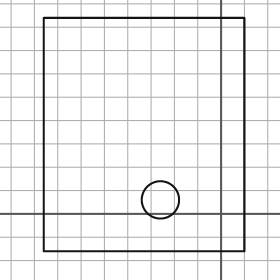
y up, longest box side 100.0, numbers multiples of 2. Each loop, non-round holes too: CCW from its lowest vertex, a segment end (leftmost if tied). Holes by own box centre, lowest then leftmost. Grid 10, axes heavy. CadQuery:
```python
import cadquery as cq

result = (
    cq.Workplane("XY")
    .moveTo(-76.0, -16.0)
    .lineTo(10.0, -16.0)
    .lineTo(10.0, 84.0)
    .lineTo(-76.0, 84.0)
    .close()
    .moveTo(-26.0, 6.0)
    .circle(8.0)
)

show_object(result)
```